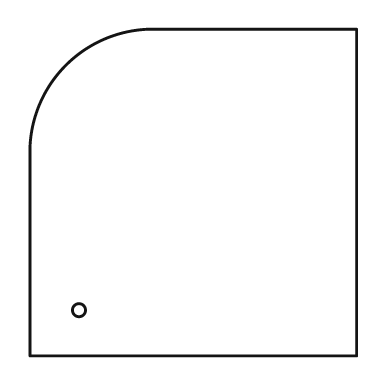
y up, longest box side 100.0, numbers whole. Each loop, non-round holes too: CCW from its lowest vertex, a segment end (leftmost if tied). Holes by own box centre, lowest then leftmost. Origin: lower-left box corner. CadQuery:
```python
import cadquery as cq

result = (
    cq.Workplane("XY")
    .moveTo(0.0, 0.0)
    .lineTo(100.0, 0.0)
    .lineTo(100.0, 100.0)
    .lineTo(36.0, 100.0)
    .threePointArc((11.0, 89.0), (0.0, 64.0))
    .close()
    .moveTo(15.0, 14.0)
    .circle(2.0)
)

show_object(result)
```